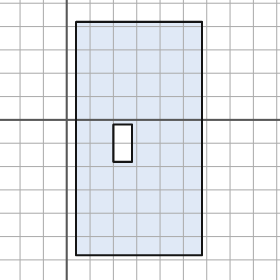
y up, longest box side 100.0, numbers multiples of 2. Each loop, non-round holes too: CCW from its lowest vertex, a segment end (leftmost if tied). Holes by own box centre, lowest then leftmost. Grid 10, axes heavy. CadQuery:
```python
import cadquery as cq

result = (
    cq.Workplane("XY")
    .moveTo(4.0, -58.0)
    .lineTo(58.0, -58.0)
    .lineTo(58.0, 42.0)
    .lineTo(4.0, 42.0)
    .close()
    .moveTo(20.0, -18.0)
    .lineTo(28.0, -18.0)
    .lineTo(28.0, -2.0)
    .lineTo(20.0, -2.0)
    .close()
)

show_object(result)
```